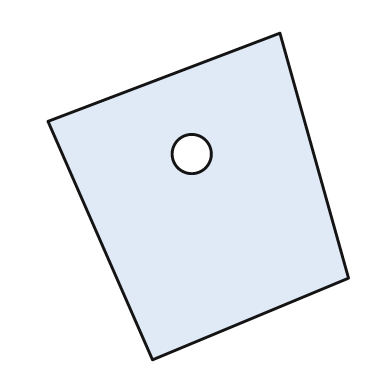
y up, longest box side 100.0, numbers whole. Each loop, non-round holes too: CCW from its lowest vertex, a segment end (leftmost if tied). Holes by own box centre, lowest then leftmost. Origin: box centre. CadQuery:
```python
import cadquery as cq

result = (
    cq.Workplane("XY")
    .moveTo(-14.0, -50.0)
    .lineTo(46.0, -25.0)
    .lineTo(25.0, 50.0)
    .lineTo(-46.0, 23.0)
    .close()
    .moveTo(-2.0, 13.0)
    .circle(6.0)
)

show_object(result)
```